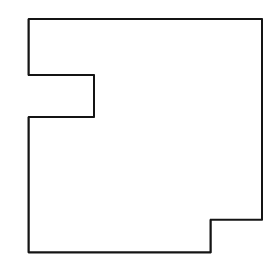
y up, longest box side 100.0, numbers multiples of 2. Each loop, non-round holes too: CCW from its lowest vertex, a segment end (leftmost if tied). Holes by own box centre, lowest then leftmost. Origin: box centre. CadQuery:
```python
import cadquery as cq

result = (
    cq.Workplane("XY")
    .moveTo(-50.0, -50.0)
    .lineTo(28.0, -50.0)
    .lineTo(28.0, -36.0)
    .lineTo(50.0, -36.0)
    .lineTo(50.0, 50.0)
    .lineTo(-50.0, 50.0)
    .lineTo(-50.0, 26.0)
    .lineTo(-22.0, 26.0)
    .lineTo(-22.0, 8.0)
    .lineTo(-50.0, 8.0)
    .close()
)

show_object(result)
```